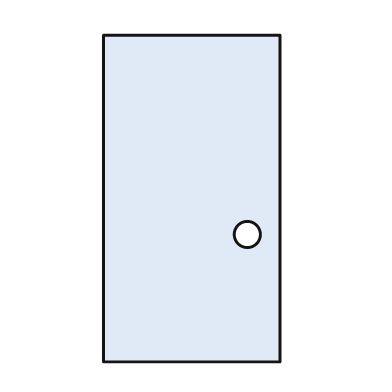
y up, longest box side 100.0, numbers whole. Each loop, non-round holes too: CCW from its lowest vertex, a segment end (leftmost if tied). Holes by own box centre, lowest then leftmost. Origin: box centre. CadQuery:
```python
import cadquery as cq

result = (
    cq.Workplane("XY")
    .moveTo(-27.0, -50.0)
    .lineTo(27.0, -50.0)
    .lineTo(27.0, 50.0)
    .lineTo(-27.0, 50.0)
    .close()
    .moveTo(17.0, -11.0)
    .circle(4.0)
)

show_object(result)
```